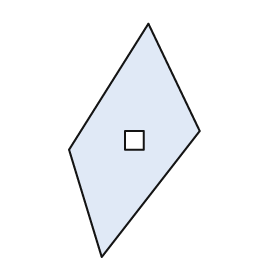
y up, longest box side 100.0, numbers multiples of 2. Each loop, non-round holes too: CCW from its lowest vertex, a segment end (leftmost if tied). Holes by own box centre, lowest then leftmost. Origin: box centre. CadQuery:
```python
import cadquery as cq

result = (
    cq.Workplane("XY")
    .moveTo(-14.0, -50.0)
    .lineTo(28.0, 4.0)
    .lineTo(6.0, 50.0)
    .lineTo(-28.0, -4.0)
    .close()
    .moveTo(-4.0, -4.0)
    .lineTo(4.0, -4.0)
    .lineTo(4.0, 4.0)
    .lineTo(-4.0, 4.0)
    .close()
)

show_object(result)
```